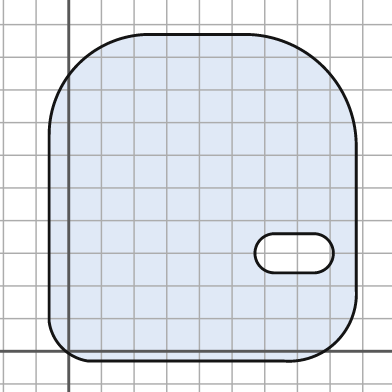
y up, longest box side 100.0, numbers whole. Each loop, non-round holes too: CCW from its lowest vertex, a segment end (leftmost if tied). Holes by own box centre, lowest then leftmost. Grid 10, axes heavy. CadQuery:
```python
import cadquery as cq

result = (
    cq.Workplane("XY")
    .moveTo(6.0, -3.0)
    .lineTo(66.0, -3.0)
    .threePointArc((82.0, 3.0), (88.0, 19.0))
    .lineTo(88.0, 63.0)
    .threePointArc((78.0, 87.0), (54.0, 97.0))
    .lineTo(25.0, 97.0)
    .threePointArc((3.0, 88.0), (-6.0, 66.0))
    .lineTo(-6.0, 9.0)
    .threePointArc((-2.0, 1.0), (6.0, -3.0))
    .close()
    .moveTo(63.0, 24.0)
    .lineTo(75.0, 24.0)
    .threePointArc((81.0, 30.0), (75.0, 36.0))
    .lineTo(63.0, 36.0)
    .threePointArc((57.0, 30.0), (63.0, 24.0))
    .close()
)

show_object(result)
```